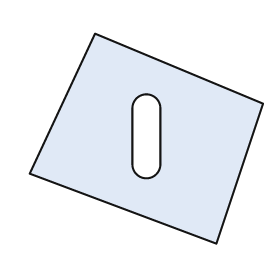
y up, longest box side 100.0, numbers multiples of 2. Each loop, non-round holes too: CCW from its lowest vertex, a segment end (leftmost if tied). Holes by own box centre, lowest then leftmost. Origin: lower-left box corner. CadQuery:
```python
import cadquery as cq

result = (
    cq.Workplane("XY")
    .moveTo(80.0, 0.0)
    .lineTo(100.0, 60.0)
    .lineTo(28.0, 90.0)
    .lineTo(0.0, 30.0)
    .close()
    .moveTo(44.0, 34.0)
    .threePointArc((50.0, 28.0), (56.0, 34.0))
    .lineTo(56.0, 58.0)
    .threePointArc((50.0, 64.0), (44.0, 58.0))
    .close()
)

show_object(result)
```